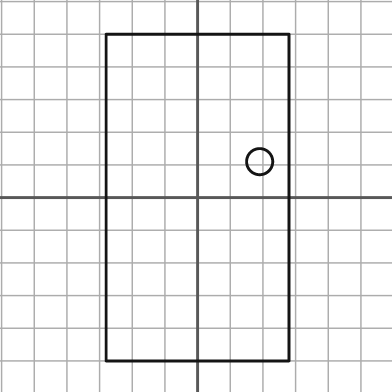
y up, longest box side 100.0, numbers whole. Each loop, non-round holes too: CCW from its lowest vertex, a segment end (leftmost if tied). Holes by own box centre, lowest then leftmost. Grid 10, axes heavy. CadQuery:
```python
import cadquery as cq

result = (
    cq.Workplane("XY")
    .moveTo(-28.0, -50.0)
    .lineTo(28.0, -50.0)
    .lineTo(28.0, 50.0)
    .lineTo(-28.0, 50.0)
    .close()
    .moveTo(19.0, 11.0)
    .circle(4.0)
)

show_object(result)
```